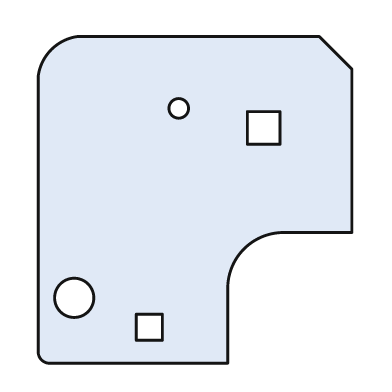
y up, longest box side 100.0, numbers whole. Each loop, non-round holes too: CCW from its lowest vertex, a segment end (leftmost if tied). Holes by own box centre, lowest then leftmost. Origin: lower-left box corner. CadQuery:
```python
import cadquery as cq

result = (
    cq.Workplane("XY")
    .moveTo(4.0, 0.0)
    .lineTo(58.0, 0.0)
    .lineTo(58.0, 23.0)
    .threePointArc((63.0, 35.0), (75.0, 40.0))
    .lineTo(96.0, 40.0)
    .lineTo(96.0, 90.0)
    .lineTo(86.0, 100.0)
    .lineTo(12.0, 100.0)
    .threePointArc((4.0, 96.0), (0.0, 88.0))
    .lineTo(0.0, 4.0)
    .threePointArc((1.0, 1.0), (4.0, 0.0))
    .close()
    .moveTo(30.0, 7.0)
    .lineTo(38.0, 7.0)
    .lineTo(38.0, 15.0)
    .lineTo(30.0, 15.0)
    .close()
    .moveTo(11.0, 20.0)
    .circle(6.0)
    .moveTo(64.0, 67.0)
    .lineTo(74.0, 67.0)
    .lineTo(74.0, 77.0)
    .lineTo(64.0, 77.0)
    .close()
    .moveTo(43.0, 78.0)
    .circle(3.0)
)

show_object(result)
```